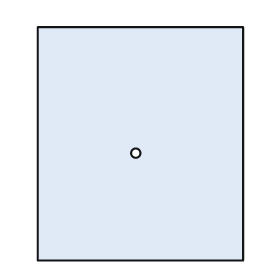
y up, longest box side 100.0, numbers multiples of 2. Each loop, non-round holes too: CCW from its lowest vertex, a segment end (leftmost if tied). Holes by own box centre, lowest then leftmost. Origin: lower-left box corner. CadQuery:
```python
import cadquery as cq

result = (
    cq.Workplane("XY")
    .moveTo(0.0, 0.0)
    .lineTo(88.0, 0.0)
    .lineTo(88.0, 100.0)
    .lineTo(0.0, 100.0)
    .close()
    .moveTo(42.0, 46.0)
    .circle(2.0)
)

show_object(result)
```